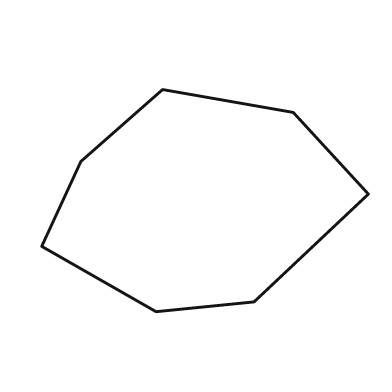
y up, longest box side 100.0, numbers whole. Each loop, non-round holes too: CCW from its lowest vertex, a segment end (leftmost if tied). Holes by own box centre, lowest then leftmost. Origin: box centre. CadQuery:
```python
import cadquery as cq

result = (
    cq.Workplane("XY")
    .moveTo(-15.0, -34.0)
    .lineTo(15.0, -31.0)
    .lineTo(50.0, 2.0)
    .lineTo(27.0, 27.0)
    .lineTo(-13.0, 34.0)
    .lineTo(-38.0, 12.0)
    .lineTo(-50.0, -14.0)
    .close()
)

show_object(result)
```